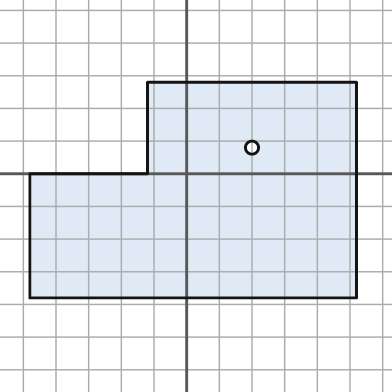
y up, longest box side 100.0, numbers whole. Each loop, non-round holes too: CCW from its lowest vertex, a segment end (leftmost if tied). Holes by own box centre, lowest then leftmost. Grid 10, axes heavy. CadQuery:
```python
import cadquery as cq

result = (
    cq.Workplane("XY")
    .moveTo(-48.0, -38.0)
    .lineTo(52.0, -38.0)
    .lineTo(52.0, 28.0)
    .lineTo(-12.0, 28.0)
    .lineTo(-12.0, 0.0)
    .lineTo(-48.0, 0.0)
    .close()
    .moveTo(20.0, 8.0)
    .circle(2.0)
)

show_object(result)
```